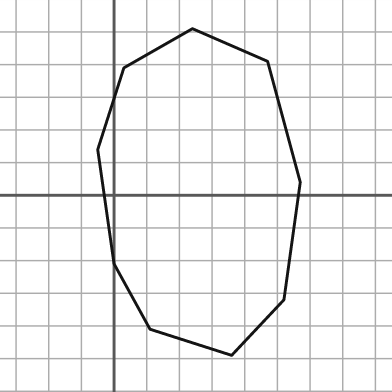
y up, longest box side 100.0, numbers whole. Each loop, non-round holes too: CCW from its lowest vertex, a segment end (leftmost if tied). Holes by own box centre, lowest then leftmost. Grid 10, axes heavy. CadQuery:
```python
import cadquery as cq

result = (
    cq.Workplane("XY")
    .moveTo(36.0, -49.0)
    .lineTo(52.0, -32.0)
    .lineTo(57.0, 4.0)
    .lineTo(47.0, 41.0)
    .lineTo(24.0, 51.0)
    .lineTo(3.0, 39.0)
    .lineTo(-5.0, 14.0)
    .lineTo(0.0, -21.0)
    .lineTo(11.0, -41.0)
    .close()
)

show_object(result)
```